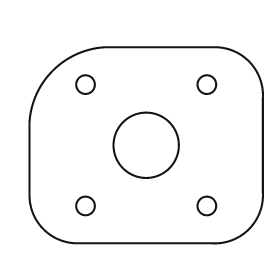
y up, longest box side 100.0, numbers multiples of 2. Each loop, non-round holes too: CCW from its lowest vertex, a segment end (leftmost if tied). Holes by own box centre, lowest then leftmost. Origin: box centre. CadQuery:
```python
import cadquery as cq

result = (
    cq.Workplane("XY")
    .moveTo(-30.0, -42.0)
    .lineTo(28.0, -42.0)
    .threePointArc((44.0, -36.0), (50.0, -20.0))
    .lineTo(50.0, 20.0)
    .threePointArc((44.0, 36.0), (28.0, 42.0))
    .lineTo(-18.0, 42.0)
    .threePointArc((-40.0, 32.0), (-50.0, 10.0))
    .lineTo(-50.0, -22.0)
    .threePointArc((-44.0, -36.0), (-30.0, -42.0))
    .close()
    .moveTo(-26.0, -26.0)
    .circle(4.0)
    .moveTo(26.0, -26.0)
    .circle(4.0)
    .moveTo(0.0, 0.0)
    .circle(14.0)
    .moveTo(-26.0, 26.0)
    .circle(4.0)
    .moveTo(26.0, 26.0)
    .circle(4.0)
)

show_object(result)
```